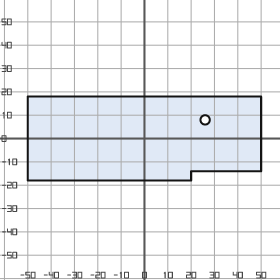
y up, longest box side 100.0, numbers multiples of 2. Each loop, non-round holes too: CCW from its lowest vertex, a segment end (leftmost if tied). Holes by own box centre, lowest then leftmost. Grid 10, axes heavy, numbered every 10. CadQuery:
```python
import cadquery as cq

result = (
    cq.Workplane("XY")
    .moveTo(-50.0, -18.0)
    .lineTo(20.0, -18.0)
    .lineTo(20.0, -14.0)
    .lineTo(50.0, -14.0)
    .lineTo(50.0, 18.0)
    .lineTo(-50.0, 18.0)
    .close()
    .moveTo(26.0, 8.0)
    .circle(2.0)
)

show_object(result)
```